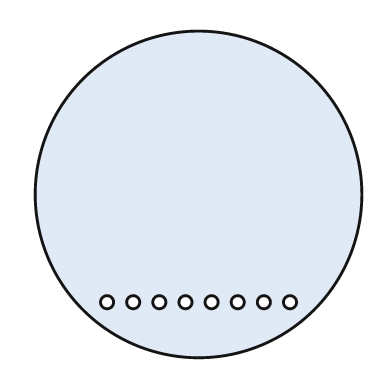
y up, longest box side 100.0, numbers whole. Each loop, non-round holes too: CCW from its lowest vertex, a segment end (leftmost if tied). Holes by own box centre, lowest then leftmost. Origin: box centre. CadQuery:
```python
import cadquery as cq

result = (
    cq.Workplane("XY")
    .moveTo(0.0, 0.0)
    .circle(50.0)
    .moveTo(-28.0, -33.0)
    .circle(2.0)
    .moveTo(-20.0, -33.0)
    .circle(2.0)
    .moveTo(-12.0, -33.0)
    .circle(2.0)
    .moveTo(-4.0, -33.0)
    .circle(2.0)
    .moveTo(4.0, -33.0)
    .circle(2.0)
    .moveTo(12.0, -33.0)
    .circle(2.0)
    .moveTo(20.0, -33.0)
    .circle(2.0)
    .moveTo(28.0, -33.0)
    .circle(2.0)
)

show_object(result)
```